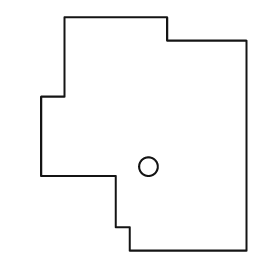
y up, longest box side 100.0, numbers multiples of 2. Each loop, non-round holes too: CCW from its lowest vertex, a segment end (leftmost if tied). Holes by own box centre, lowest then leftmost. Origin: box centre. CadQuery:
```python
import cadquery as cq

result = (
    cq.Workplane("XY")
    .moveTo(-6.0, -50.0)
    .lineTo(44.0, -50.0)
    .lineTo(44.0, 40.0)
    .lineTo(10.0, 40.0)
    .lineTo(10.0, 50.0)
    .lineTo(-34.0, 50.0)
    .lineTo(-34.0, 16.0)
    .lineTo(-44.0, 16.0)
    .lineTo(-44.0, -18.0)
    .lineTo(-12.0, -18.0)
    .lineTo(-12.0, -40.0)
    .lineTo(-6.0, -40.0)
    .close()
    .moveTo(2.0, -14.0)
    .circle(4.0)
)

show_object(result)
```